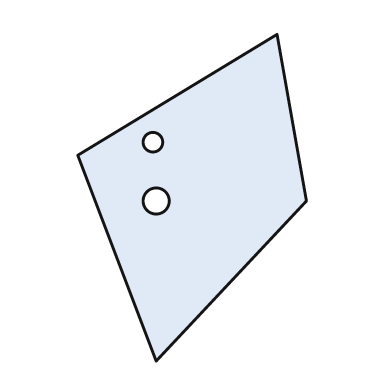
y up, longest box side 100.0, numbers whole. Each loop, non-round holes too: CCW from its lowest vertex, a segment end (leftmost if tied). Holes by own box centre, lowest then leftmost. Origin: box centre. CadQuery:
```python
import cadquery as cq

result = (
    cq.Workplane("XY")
    .moveTo(-11.0, -50.0)
    .lineTo(35.0, -1.0)
    .lineTo(26.0, 50.0)
    .lineTo(-35.0, 13.0)
    .close()
    .moveTo(-11.0, -1.0)
    .circle(4.0)
    .moveTo(-12.0, 17.0)
    .circle(3.0)
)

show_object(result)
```